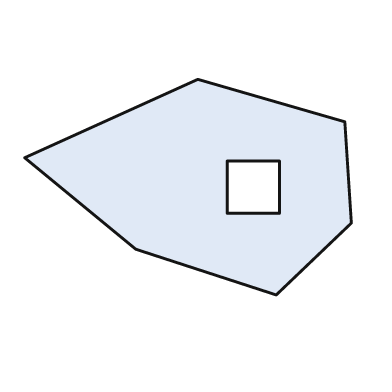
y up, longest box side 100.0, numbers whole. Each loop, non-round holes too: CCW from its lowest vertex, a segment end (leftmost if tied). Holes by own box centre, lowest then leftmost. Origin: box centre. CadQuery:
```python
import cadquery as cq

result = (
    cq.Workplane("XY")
    .moveTo(27.0, -33.0)
    .lineTo(50.0, -11.0)
    .lineTo(48.0, 20.0)
    .lineTo(3.0, 33.0)
    .lineTo(-50.0, 9.0)
    .lineTo(-16.0, -19.0)
    .close()
    .moveTo(12.0, -8.0)
    .lineTo(28.0, -8.0)
    .lineTo(28.0, 8.0)
    .lineTo(12.0, 8.0)
    .close()
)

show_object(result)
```